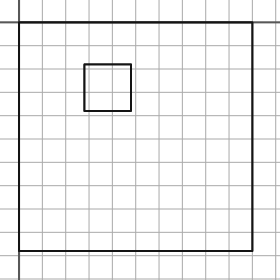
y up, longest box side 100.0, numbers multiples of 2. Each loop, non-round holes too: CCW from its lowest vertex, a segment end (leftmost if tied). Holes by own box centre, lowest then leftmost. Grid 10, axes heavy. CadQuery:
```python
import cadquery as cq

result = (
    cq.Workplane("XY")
    .moveTo(0.0, -98.0)
    .lineTo(100.0, -98.0)
    .lineTo(100.0, 0.0)
    .lineTo(0.0, 0.0)
    .close()
    .moveTo(28.0, -38.0)
    .lineTo(48.0, -38.0)
    .lineTo(48.0, -18.0)
    .lineTo(28.0, -18.0)
    .close()
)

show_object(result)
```